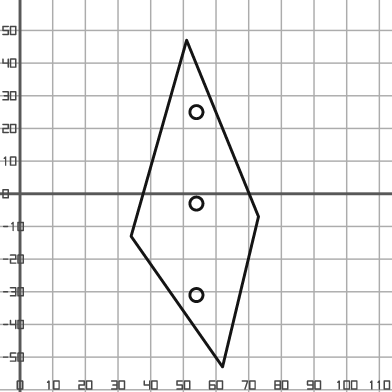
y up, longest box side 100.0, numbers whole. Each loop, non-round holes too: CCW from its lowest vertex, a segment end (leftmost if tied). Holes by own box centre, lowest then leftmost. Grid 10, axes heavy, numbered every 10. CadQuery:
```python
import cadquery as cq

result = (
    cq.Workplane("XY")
    .moveTo(62.0, -53.0)
    .lineTo(73.0, -7.0)
    .lineTo(51.0, 47.0)
    .lineTo(34.0, -13.0)
    .close()
    .moveTo(54.0, -31.0)
    .circle(2.0)
    .moveTo(54.0, -3.0)
    .circle(2.0)
    .moveTo(54.0, 25.0)
    .circle(2.0)
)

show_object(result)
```